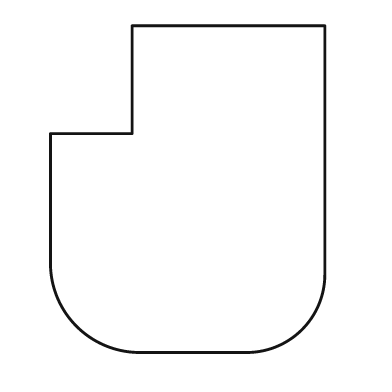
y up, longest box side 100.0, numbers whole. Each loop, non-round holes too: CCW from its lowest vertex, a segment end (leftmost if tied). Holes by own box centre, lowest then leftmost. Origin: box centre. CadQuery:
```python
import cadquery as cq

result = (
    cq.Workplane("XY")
    .moveTo(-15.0, -50.0)
    .lineTo(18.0, -50.0)
    .threePointArc((35.0, -43.0), (42.0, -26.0))
    .lineTo(42.0, 50.0)
    .lineTo(-17.0, 50.0)
    .lineTo(-17.0, 17.0)
    .lineTo(-42.0, 17.0)
    .lineTo(-42.0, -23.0)
    .threePointArc((-34.0, -42.0), (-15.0, -50.0))
    .close()
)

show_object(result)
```